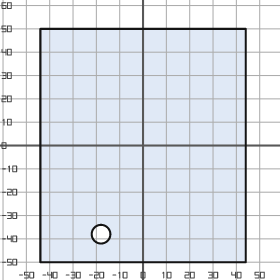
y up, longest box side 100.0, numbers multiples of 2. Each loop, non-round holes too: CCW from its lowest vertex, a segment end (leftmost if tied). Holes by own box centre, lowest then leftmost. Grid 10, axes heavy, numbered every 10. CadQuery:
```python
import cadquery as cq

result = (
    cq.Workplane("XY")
    .moveTo(-44.0, -50.0)
    .lineTo(44.0, -50.0)
    .lineTo(44.0, 50.0)
    .lineTo(-44.0, 50.0)
    .close()
    .moveTo(-18.0, -38.0)
    .circle(4.0)
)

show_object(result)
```